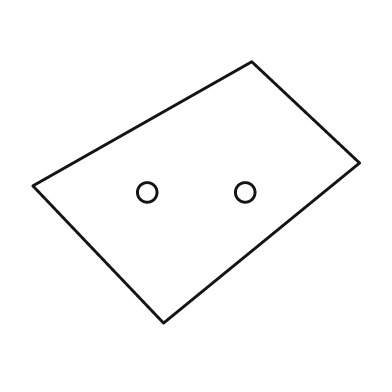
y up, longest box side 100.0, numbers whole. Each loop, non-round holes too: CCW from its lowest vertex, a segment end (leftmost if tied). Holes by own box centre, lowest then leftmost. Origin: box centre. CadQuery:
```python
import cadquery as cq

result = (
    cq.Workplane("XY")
    .moveTo(-10.0, -40.0)
    .lineTo(50.0, 9.0)
    .lineTo(17.0, 40.0)
    .lineTo(-50.0, 2.0)
    .close()
    .moveTo(-15.0, 0.0)
    .circle(3.0)
    .moveTo(15.0, 0.0)
    .circle(3.0)
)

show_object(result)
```